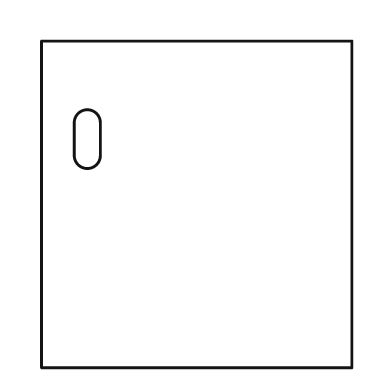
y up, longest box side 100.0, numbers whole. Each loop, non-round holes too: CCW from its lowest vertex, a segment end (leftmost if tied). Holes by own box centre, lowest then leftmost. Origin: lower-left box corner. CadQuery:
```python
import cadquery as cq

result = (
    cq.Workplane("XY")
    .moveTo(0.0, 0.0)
    .lineTo(95.0, 0.0)
    .lineTo(95.0, 100.0)
    .lineTo(0.0, 100.0)
    .close()
    .moveTo(10.0, 65.0)
    .threePointArc((14.0, 61.0), (18.0, 65.0))
    .lineTo(18.0, 75.0)
    .threePointArc((14.0, 79.0), (10.0, 75.0))
    .close()
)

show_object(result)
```